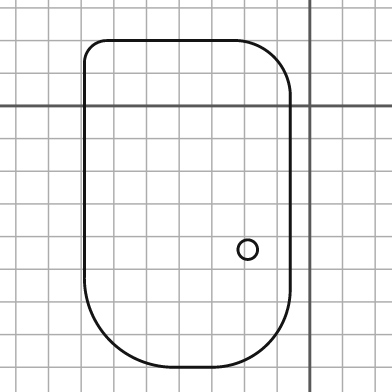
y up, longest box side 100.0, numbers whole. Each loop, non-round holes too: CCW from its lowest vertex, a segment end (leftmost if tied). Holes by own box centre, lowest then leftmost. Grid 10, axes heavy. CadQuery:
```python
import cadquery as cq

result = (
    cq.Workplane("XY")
    .moveTo(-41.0, -80.0)
    .lineTo(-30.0, -80.0)
    .threePointArc((-13.0, -73.0), (-6.0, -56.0))
    .lineTo(-6.0, 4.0)
    .threePointArc((-11.0, 15.0), (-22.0, 20.0))
    .lineTo(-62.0, 20.0)
    .threePointArc((-67.0, 18.0), (-69.0, 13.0))
    .lineTo(-69.0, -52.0)
    .threePointArc((-61.0, -72.0), (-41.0, -80.0))
    .close()
    .moveTo(-19.0, -44.0)
    .circle(3.0)
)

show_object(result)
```